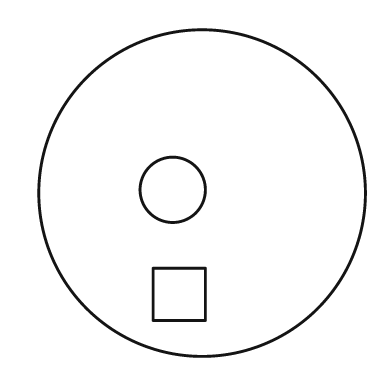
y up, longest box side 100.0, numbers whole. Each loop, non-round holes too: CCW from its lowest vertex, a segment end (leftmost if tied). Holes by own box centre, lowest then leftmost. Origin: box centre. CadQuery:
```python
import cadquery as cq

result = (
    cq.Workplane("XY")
    .moveTo(0.0, 0.0)
    .circle(50.0)
    .moveTo(-15.0, -39.0)
    .lineTo(1.0, -39.0)
    .lineTo(1.0, -23.0)
    .lineTo(-15.0, -23.0)
    .close()
    .moveTo(-9.0, 1.0)
    .circle(10.0)
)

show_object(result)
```